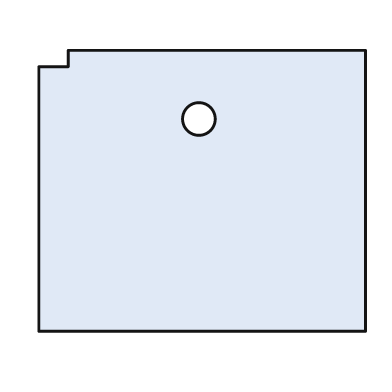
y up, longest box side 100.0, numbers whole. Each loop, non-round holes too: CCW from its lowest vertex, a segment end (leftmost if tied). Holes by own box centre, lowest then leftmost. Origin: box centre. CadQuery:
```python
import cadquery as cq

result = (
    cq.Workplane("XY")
    .moveTo(-50.0, -43.0)
    .lineTo(50.0, -43.0)
    .lineTo(50.0, 43.0)
    .lineTo(-41.0, 43.0)
    .lineTo(-41.0, 38.0)
    .lineTo(-50.0, 38.0)
    .close()
    .moveTo(-1.0, 22.0)
    .circle(5.0)
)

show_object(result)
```